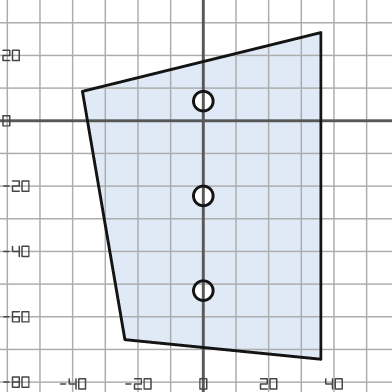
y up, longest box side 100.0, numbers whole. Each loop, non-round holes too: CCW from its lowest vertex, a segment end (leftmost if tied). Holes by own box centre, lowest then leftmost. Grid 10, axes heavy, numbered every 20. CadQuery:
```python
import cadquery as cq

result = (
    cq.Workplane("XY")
    .moveTo(36.0, -73.0)
    .lineTo(36.0, 27.0)
    .lineTo(-37.0, 9.0)
    .lineTo(-24.0, -67.0)
    .close()
    .moveTo(0.0, -52.0)
    .circle(3.0)
    .moveTo(0.0, -23.0)
    .circle(3.0)
    .moveTo(0.0, 6.0)
    .circle(3.0)
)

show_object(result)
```